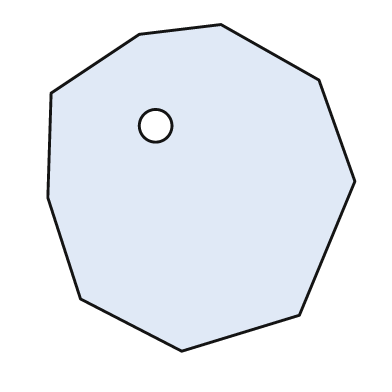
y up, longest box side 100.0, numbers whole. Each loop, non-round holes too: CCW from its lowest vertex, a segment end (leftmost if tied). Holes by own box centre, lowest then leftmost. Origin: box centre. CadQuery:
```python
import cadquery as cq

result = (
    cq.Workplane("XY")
    .moveTo(-6.0, -50.0)
    .lineTo(30.0, -39.0)
    .lineTo(47.0, 2.0)
    .lineTo(36.0, 33.0)
    .lineTo(6.0, 50.0)
    .lineTo(-19.0, 47.0)
    .lineTo(-46.0, 29.0)
    .lineTo(-47.0, -3.0)
    .lineTo(-37.0, -34.0)
    .close()
    .moveTo(-14.0, 19.0)
    .circle(5.0)
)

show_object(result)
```